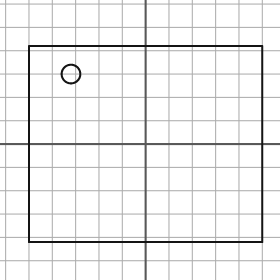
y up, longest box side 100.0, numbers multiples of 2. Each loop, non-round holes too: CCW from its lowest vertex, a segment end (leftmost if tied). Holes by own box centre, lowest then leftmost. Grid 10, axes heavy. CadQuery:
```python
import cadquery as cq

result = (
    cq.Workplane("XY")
    .moveTo(-50.0, -42.0)
    .lineTo(50.0, -42.0)
    .lineTo(50.0, 42.0)
    .lineTo(-50.0, 42.0)
    .close()
    .moveTo(-32.0, 30.0)
    .circle(4.0)
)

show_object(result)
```